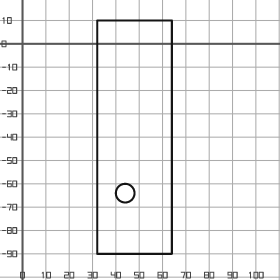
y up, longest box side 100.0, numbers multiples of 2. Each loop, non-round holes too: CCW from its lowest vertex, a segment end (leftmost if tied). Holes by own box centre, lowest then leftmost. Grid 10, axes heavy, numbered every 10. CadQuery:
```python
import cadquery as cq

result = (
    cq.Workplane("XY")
    .moveTo(32.0, -90.0)
    .lineTo(64.0, -90.0)
    .lineTo(64.0, 10.0)
    .lineTo(32.0, 10.0)
    .close()
    .moveTo(44.0, -64.0)
    .circle(4.0)
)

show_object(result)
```